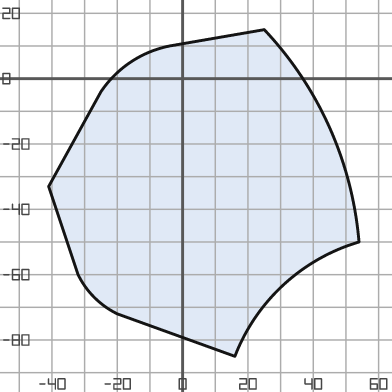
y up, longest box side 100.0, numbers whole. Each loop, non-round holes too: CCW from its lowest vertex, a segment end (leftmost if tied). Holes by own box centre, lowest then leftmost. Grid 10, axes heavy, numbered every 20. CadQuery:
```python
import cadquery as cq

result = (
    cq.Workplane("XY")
    .moveTo(16.0, -85.0)
    .threePointArc((31.0, -63.0), (54.0, -50.0))
    .threePointArc((45.0, -15.0), (25.0, 15.0))
    .lineTo(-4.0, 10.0)
    .threePointArc((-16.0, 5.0), (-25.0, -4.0))
    .lineTo(-41.0, -33.0)
    .lineTo(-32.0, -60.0)
    .threePointArc((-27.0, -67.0), (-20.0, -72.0))
    .close()
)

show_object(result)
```